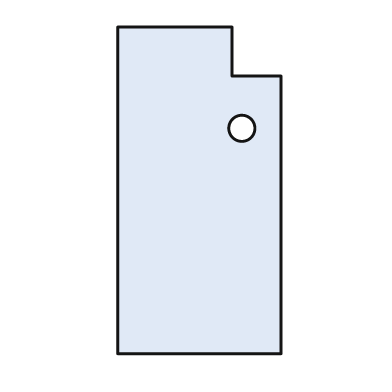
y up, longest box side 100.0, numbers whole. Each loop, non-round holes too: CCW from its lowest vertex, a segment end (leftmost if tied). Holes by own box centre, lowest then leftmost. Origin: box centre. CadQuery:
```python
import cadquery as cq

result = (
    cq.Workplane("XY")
    .moveTo(-25.0, -50.0)
    .lineTo(25.0, -50.0)
    .lineTo(25.0, 35.0)
    .lineTo(10.0, 35.0)
    .lineTo(10.0, 50.0)
    .lineTo(-25.0, 50.0)
    .close()
    .moveTo(13.0, 19.0)
    .circle(4.0)
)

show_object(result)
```